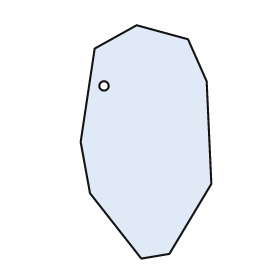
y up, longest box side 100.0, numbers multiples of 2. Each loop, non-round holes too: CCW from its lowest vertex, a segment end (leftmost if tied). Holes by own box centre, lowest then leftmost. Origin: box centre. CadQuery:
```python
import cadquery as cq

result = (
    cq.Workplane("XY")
    .moveTo(-2.0, -50.0)
    .lineTo(10.0, -48.0)
    .lineTo(28.0, -18.0)
    .lineTo(26.0, 26.0)
    .lineTo(18.0, 44.0)
    .lineTo(-4.0, 50.0)
    .lineTo(-22.0, 40.0)
    .lineTo(-28.0, 0.0)
    .lineTo(-24.0, -22.0)
    .close()
    .moveTo(-18.0, 24.0)
    .circle(2.0)
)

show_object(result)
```